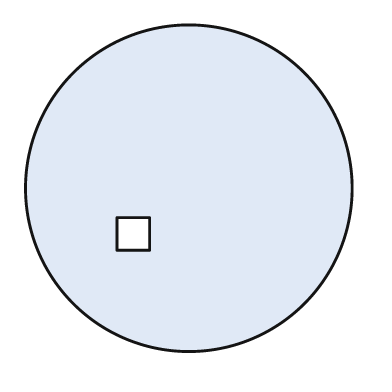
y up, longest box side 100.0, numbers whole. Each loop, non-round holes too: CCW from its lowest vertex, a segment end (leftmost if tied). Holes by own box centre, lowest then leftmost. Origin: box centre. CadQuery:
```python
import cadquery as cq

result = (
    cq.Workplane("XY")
    .moveTo(0.0, 0.0)
    .circle(50.0)
    .moveTo(-22.0, -19.0)
    .lineTo(-12.0, -19.0)
    .lineTo(-12.0, -9.0)
    .lineTo(-22.0, -9.0)
    .close()
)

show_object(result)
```